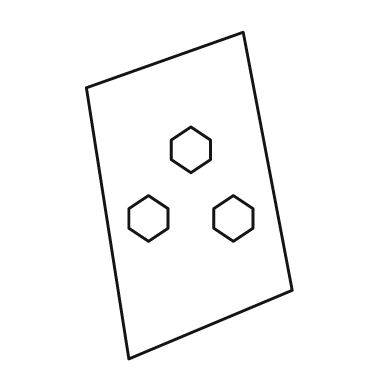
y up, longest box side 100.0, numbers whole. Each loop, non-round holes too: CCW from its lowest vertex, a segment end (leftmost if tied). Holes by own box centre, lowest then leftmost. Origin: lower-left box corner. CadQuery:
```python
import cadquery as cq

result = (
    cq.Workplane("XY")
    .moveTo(13.0, 0.0)
    .lineTo(63.0, 21.0)
    .lineTo(48.0, 100.0)
    .lineTo(0.0, 83.0)
    .close()
    .moveTo(19.0, 36.0)
    .lineTo(25.0, 40.0)
    .lineTo(25.0, 46.0)
    .lineTo(19.0, 50.0)
    .lineTo(13.0, 46.0)
    .lineTo(13.0, 40.0)
    .close()
    .moveTo(45.0, 36.0)
    .lineTo(51.0, 40.0)
    .lineTo(51.0, 46.0)
    .lineTo(45.0, 50.0)
    .lineTo(39.0, 46.0)
    .lineTo(39.0, 40.0)
    .close()
    .moveTo(32.0, 57.0)
    .lineTo(38.0, 61.0)
    .lineTo(38.0, 67.0)
    .lineTo(32.0, 71.0)
    .lineTo(26.0, 67.0)
    .lineTo(26.0, 61.0)
    .close()
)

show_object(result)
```